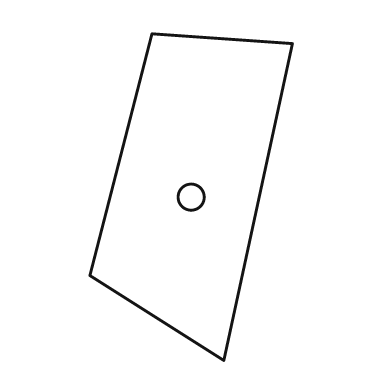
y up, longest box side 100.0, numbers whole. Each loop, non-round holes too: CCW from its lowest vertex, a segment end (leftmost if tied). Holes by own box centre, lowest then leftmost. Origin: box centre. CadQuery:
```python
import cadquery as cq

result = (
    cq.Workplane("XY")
    .moveTo(10.0, -50.0)
    .lineTo(31.0, 47.0)
    .lineTo(-12.0, 50.0)
    .lineTo(-31.0, -24.0)
    .close()
    .moveTo(0.0, 0.0)
    .circle(4.0)
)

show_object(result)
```